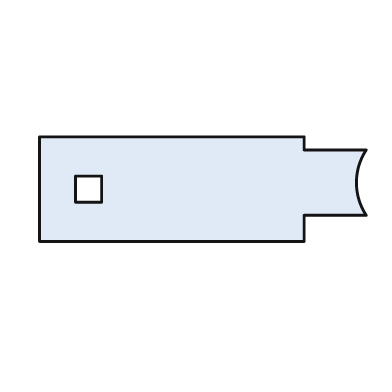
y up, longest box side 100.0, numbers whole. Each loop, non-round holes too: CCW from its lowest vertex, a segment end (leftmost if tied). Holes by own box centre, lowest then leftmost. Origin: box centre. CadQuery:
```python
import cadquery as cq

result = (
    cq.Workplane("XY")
    .moveTo(-50.0, -16.0)
    .lineTo(31.0, -16.0)
    .lineTo(31.0, -8.0)
    .lineTo(50.0, -8.0)
    .threePointArc((47.0, 2.0), (50.0, 12.0))
    .lineTo(31.0, 12.0)
    .lineTo(31.0, 16.0)
    .lineTo(-50.0, 16.0)
    .close()
    .moveTo(-39.0, -4.0)
    .lineTo(-31.0, -4.0)
    .lineTo(-31.0, 4.0)
    .lineTo(-39.0, 4.0)
    .close()
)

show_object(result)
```